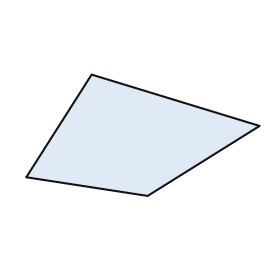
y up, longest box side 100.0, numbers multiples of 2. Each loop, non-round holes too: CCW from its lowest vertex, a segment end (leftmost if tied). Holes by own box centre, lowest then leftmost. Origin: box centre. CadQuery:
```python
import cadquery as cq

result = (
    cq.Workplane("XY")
    .moveTo(2.0, -26.0)
    .lineTo(50.0, 4.0)
    .lineTo(-22.0, 26.0)
    .lineTo(-50.0, -18.0)
    .close()
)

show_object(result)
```